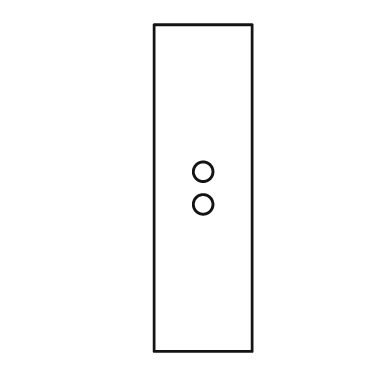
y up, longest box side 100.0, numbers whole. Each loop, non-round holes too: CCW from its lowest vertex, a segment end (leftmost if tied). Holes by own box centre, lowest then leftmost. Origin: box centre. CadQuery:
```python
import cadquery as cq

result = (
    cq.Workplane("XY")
    .moveTo(-15.0, -50.0)
    .lineTo(15.0, -50.0)
    .lineTo(15.0, 50.0)
    .lineTo(-15.0, 50.0)
    .close()
    .moveTo(0.0, -5.0)
    .circle(3.0)
    .moveTo(0.0, 5.0)
    .circle(3.0)
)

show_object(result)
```